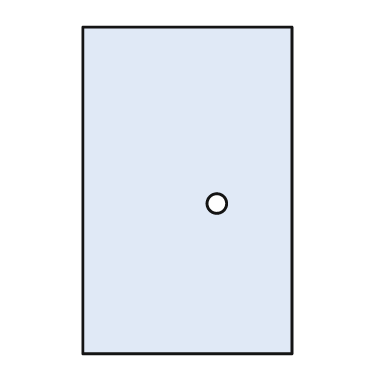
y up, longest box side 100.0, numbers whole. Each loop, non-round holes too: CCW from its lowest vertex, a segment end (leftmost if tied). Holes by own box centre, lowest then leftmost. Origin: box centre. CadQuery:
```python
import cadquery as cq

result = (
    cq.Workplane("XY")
    .moveTo(-32.0, -50.0)
    .lineTo(32.0, -50.0)
    .lineTo(32.0, 50.0)
    .lineTo(-32.0, 50.0)
    .close()
    .moveTo(9.0, -4.0)
    .circle(3.0)
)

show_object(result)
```